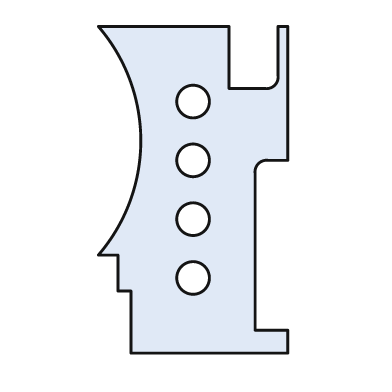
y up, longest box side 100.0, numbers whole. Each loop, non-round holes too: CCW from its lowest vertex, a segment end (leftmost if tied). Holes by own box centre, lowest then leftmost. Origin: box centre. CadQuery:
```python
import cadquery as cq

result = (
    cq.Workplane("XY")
    .moveTo(-19.0, -50.0)
    .lineTo(29.0, -50.0)
    .lineTo(29.0, -43.0)
    .lineTo(19.0, -43.0)
    .lineTo(19.0, 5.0)
    .threePointArc((20.0, 8.0), (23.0, 9.0))
    .lineTo(29.0, 9.0)
    .lineTo(29.0, 50.0)
    .lineTo(26.0, 50.0)
    .lineTo(26.0, 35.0)
    .threePointArc((25.0, 32.0), (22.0, 31.0))
    .lineTo(11.0, 31.0)
    .lineTo(11.0, 50.0)
    .lineTo(-29.0, 50.0)
    .threePointArc((-16.0, 15.0), (-29.0, -20.0))
    .lineTo(-23.0, -20.0)
    .lineTo(-23.0, -31.0)
    .lineTo(-19.0, -31.0)
    .close()
    .moveTo(0.0, -27.0)
    .circle(5.0)
    .moveTo(0.0, -9.0)
    .circle(5.0)
    .moveTo(0.0, 9.0)
    .circle(5.0)
    .moveTo(0.0, 27.0)
    .circle(5.0)
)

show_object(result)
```